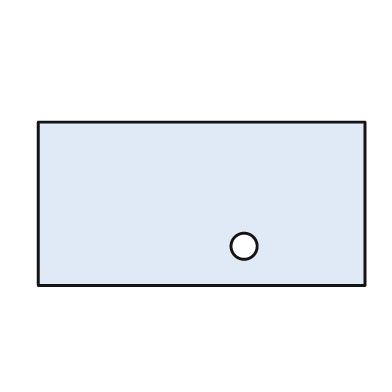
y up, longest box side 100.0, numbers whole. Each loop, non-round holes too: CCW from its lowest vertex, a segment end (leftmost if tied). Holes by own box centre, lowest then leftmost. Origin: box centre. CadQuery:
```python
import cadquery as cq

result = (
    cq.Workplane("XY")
    .moveTo(-50.0, -25.0)
    .lineTo(50.0, -25.0)
    .lineTo(50.0, 25.0)
    .lineTo(-50.0, 25.0)
    .close()
    .moveTo(13.0, -13.0)
    .circle(4.0)
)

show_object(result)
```